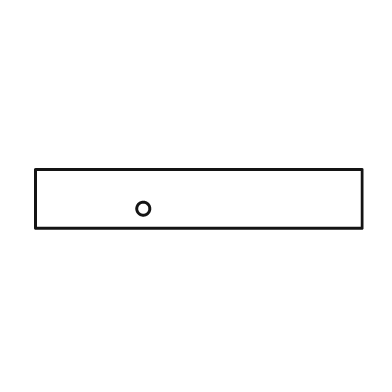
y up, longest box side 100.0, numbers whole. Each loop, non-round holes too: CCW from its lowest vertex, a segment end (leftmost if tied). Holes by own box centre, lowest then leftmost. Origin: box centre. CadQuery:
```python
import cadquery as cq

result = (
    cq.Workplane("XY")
    .moveTo(-50.0, -9.0)
    .lineTo(50.0, -9.0)
    .lineTo(50.0, 9.0)
    .lineTo(-50.0, 9.0)
    .close()
    .moveTo(-17.0, -3.0)
    .circle(2.0)
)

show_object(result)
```